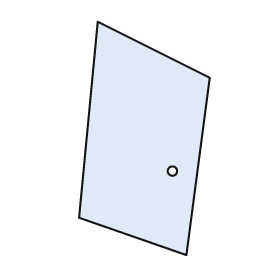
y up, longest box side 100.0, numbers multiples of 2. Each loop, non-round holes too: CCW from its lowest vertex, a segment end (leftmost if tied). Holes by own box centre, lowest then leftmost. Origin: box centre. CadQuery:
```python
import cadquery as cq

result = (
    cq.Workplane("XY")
    .moveTo(18.0, -50.0)
    .lineTo(28.0, 26.0)
    .lineTo(-20.0, 50.0)
    .lineTo(-28.0, -34.0)
    .close()
    .moveTo(12.0, -14.0)
    .circle(2.0)
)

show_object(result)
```